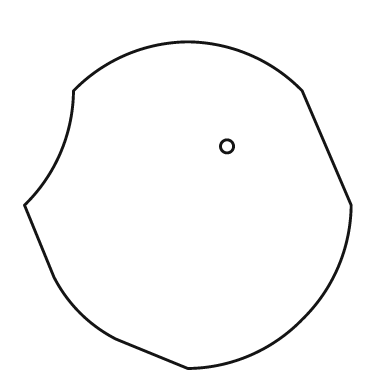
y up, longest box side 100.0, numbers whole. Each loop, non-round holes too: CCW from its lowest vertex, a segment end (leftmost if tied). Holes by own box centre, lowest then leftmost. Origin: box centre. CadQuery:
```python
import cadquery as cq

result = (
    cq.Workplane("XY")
    .moveTo(0.0, -50.0)
    .threePointArc((19.0, -46.0), (35.0, -35.0))
    .threePointArc((46.0, -19.0), (50.0, 0.0))
    .lineTo(35.0, 35.0)
    .threePointArc((19.0, 46.0), (0.0, 50.0))
    .threePointArc((-19.0, 46.0), (-35.0, 35.0))
    .threePointArc((-39.0, 16.0), (-50.0, 0.0))
    .lineTo(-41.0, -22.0)
    .threePointArc((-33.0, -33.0), (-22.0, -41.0))
    .close()
    .moveTo(12.0, 18.0)
    .circle(2.0)
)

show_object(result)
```